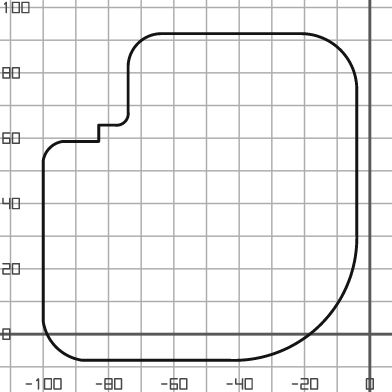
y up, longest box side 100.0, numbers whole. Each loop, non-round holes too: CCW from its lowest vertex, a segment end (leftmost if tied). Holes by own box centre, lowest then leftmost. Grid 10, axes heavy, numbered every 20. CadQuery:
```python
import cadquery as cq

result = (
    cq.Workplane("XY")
    .moveTo(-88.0, -8.0)
    .lineTo(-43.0, -8.0)
    .threePointArc((-15.0, 3.0), (-4.0, 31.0))
    .lineTo(-4.0, 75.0)
    .threePointArc((-9.0, 87.0), (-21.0, 92.0))
    .lineTo(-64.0, 92.0)
    .threePointArc((-71.0, 89.0), (-74.0, 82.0))
    .lineTo(-74.0, 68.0)
    .threePointArc((-75.0, 65.0), (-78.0, 64.0))
    .lineTo(-83.0, 64.0)
    .lineTo(-83.0, 59.0)
    .lineTo(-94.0, 59.0)
    .threePointArc((-98.0, 57.0), (-100.0, 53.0))
    .lineTo(-100.0, 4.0)
    .threePointArc((-96.0, -4.0), (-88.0, -8.0))
    .close()
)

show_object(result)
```